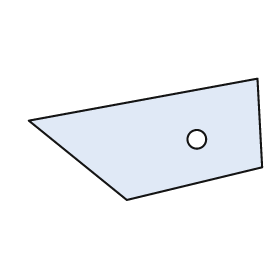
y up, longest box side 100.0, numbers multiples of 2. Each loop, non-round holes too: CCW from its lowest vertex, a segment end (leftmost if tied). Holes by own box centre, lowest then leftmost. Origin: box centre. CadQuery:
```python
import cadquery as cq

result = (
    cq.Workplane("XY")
    .moveTo(-8.0, -26.0)
    .lineTo(50.0, -12.0)
    .lineTo(48.0, 26.0)
    .lineTo(-50.0, 8.0)
    .close()
    .moveTo(22.0, 0.0)
    .circle(4.0)
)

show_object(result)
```